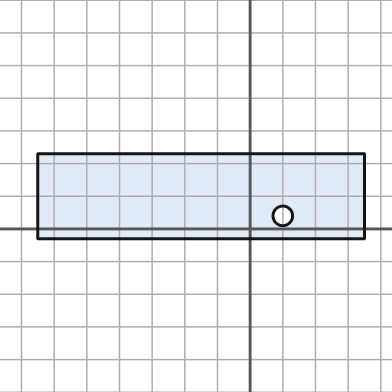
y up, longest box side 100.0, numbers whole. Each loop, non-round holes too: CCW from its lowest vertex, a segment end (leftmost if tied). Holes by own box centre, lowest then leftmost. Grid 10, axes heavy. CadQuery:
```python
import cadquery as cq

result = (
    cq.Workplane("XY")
    .moveTo(-65.0, -3.0)
    .lineTo(35.0, -3.0)
    .lineTo(35.0, 23.0)
    .lineTo(-65.0, 23.0)
    .close()
    .moveTo(10.0, 4.0)
    .circle(3.0)
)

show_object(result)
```